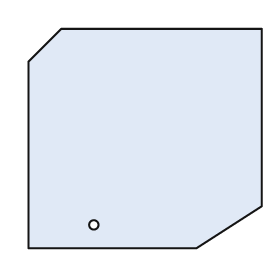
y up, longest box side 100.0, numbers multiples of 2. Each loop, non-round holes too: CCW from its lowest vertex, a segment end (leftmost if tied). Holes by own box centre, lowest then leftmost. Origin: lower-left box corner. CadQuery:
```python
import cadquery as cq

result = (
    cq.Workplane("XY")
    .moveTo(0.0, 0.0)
    .lineTo(72.0, 0.0)
    .lineTo(100.0, 18.0)
    .lineTo(100.0, 94.0)
    .lineTo(14.0, 94.0)
    .lineTo(0.0, 80.0)
    .close()
    .moveTo(28.0, 10.0)
    .circle(2.0)
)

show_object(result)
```